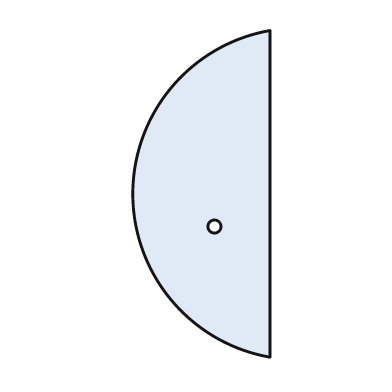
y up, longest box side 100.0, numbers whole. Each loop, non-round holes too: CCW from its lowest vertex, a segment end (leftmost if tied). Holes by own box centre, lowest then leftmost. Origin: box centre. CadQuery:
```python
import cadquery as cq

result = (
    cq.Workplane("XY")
    .moveTo(21.0, -50.0)
    .lineTo(21.0, 50.0)
    .threePointArc((-21.0, 0.0), (21.0, -50.0))
    .close()
    .moveTo(4.0, -10.0)
    .circle(2.0)
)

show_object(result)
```